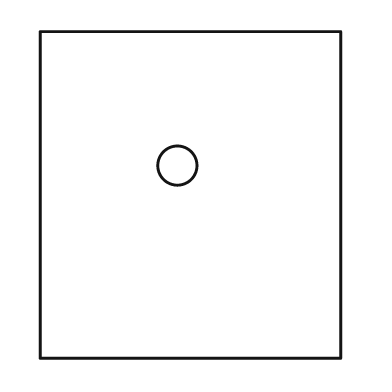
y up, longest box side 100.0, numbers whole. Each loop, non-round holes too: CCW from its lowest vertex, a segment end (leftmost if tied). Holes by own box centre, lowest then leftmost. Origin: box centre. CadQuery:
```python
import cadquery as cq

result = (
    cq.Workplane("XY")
    .moveTo(-46.0, -50.0)
    .lineTo(46.0, -50.0)
    .lineTo(46.0, 50.0)
    .lineTo(-46.0, 50.0)
    .close()
    .moveTo(-4.0, 9.0)
    .circle(6.0)
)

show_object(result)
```